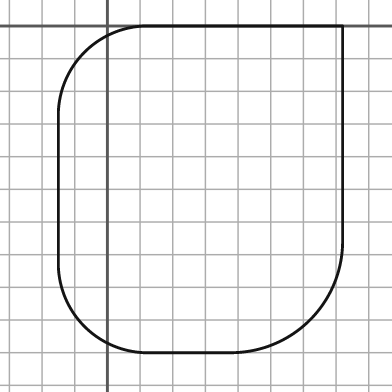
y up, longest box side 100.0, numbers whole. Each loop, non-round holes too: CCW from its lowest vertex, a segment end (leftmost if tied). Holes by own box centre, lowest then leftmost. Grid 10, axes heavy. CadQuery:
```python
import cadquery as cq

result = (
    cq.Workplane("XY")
    .moveTo(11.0, -100.0)
    .lineTo(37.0, -100.0)
    .threePointArc((62.0, -90.0), (72.0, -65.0))
    .lineTo(72.0, 0.0)
    .lineTo(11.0, 0.0)
    .threePointArc((-7.0, -8.0), (-15.0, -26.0))
    .lineTo(-15.0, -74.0)
    .threePointArc((-7.0, -92.0), (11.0, -100.0))
    .close()
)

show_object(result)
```